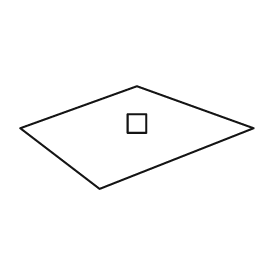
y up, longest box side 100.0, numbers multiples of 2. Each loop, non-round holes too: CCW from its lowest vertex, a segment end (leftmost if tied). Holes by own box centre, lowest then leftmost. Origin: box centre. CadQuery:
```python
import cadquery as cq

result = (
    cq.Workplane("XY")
    .moveTo(-16.0, -22.0)
    .lineTo(50.0, 4.0)
    .lineTo(0.0, 22.0)
    .lineTo(-50.0, 4.0)
    .close()
    .moveTo(-4.0, 2.0)
    .lineTo(4.0, 2.0)
    .lineTo(4.0, 10.0)
    .lineTo(-4.0, 10.0)
    .close()
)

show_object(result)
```